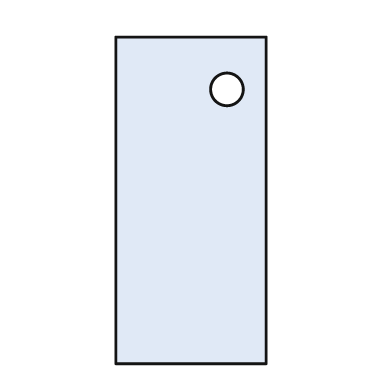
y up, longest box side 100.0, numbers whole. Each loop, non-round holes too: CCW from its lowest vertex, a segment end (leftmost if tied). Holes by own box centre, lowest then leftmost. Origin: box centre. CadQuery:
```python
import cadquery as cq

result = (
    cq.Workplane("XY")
    .moveTo(-23.0, -50.0)
    .lineTo(23.0, -50.0)
    .lineTo(23.0, 50.0)
    .lineTo(-23.0, 50.0)
    .close()
    .moveTo(11.0, 34.0)
    .circle(5.0)
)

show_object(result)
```